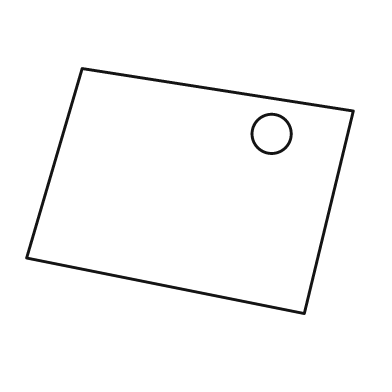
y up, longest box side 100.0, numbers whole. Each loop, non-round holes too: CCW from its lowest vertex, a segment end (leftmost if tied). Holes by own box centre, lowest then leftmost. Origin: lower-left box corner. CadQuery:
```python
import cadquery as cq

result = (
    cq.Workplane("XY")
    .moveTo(85.0, 0.0)
    .lineTo(100.0, 62.0)
    .lineTo(17.0, 75.0)
    .lineTo(0.0, 17.0)
    .close()
    .moveTo(75.0, 55.0)
    .circle(6.0)
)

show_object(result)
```